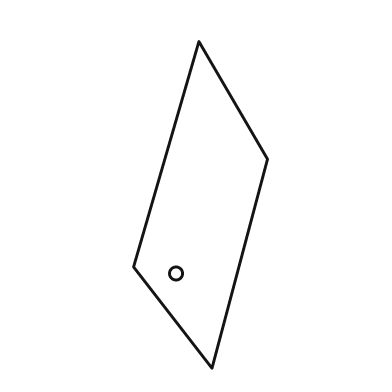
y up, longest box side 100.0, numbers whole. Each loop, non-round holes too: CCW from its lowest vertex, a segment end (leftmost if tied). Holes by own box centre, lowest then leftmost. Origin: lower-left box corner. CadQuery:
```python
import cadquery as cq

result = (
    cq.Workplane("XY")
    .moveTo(24.0, 0.0)
    .lineTo(41.0, 64.0)
    .lineTo(20.0, 100.0)
    .lineTo(0.0, 31.0)
    .close()
    .moveTo(13.0, 29.0)
    .circle(2.0)
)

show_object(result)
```